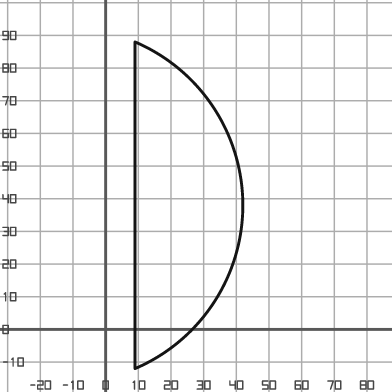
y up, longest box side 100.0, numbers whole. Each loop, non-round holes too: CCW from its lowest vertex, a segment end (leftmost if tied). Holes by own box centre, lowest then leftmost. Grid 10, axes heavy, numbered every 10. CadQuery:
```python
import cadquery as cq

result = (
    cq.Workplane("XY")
    .moveTo(9.0, -12.0)
    .threePointArc((42.0, 38.0), (9.0, 88.0))
    .close()
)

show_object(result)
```